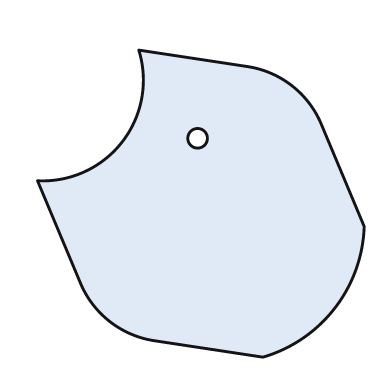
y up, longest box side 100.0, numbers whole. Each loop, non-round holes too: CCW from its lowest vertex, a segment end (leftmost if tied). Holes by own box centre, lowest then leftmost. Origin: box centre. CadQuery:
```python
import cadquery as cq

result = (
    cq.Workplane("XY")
    .moveTo(19.0, -47.0)
    .threePointArc((41.0, -32.0), (50.0, -7.0))
    .lineTo(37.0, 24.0)
    .threePointArc((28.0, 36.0), (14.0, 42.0))
    .lineTo(-19.0, 47.0)
    .threePointArc((-24.0, 19.0), (-50.0, 7.0))
    .lineTo(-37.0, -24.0)
    .threePointArc((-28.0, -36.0), (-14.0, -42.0))
    .close()
    .moveTo(-1.0, 20.0)
    .circle(3.0)
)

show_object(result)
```